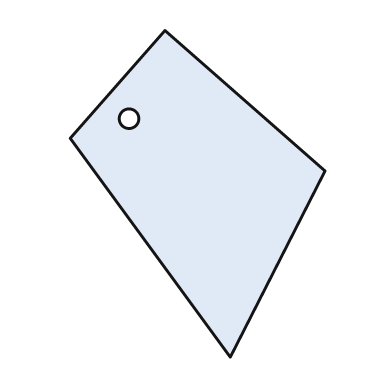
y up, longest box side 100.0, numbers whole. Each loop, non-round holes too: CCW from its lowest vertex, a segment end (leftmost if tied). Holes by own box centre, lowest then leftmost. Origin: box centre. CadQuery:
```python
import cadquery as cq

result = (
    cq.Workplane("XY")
    .moveTo(10.0, -50.0)
    .lineTo(39.0, 7.0)
    .lineTo(-10.0, 50.0)
    .lineTo(-39.0, 17.0)
    .close()
    .moveTo(-21.0, 23.0)
    .circle(3.0)
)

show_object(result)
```